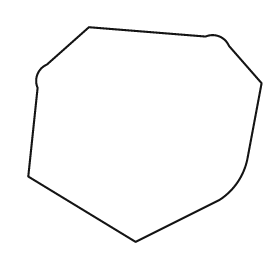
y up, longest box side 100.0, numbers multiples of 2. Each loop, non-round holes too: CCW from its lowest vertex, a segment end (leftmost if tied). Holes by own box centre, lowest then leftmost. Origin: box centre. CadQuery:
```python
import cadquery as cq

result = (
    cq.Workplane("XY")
    .moveTo(-4.0, -46.0)
    .lineTo(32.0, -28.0)
    .threePointArc((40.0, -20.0), (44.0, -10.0))
    .lineTo(50.0, 22.0)
    .lineTo(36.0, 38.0)
    .threePointArc((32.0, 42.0), (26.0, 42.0))
    .lineTo(-24.0, 46.0)
    .lineTo(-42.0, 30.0)
    .threePointArc((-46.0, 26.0), (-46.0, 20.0))
    .lineTo(-50.0, -18.0)
    .close()
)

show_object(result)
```